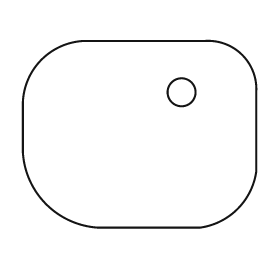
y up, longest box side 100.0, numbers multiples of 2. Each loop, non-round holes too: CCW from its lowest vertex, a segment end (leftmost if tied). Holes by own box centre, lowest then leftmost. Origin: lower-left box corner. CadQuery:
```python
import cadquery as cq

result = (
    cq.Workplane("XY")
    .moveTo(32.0, 0.0)
    .lineTo(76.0, 0.0)
    .threePointArc((92.0, 8.0), (100.0, 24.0))
    .lineTo(100.0, 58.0)
    .threePointArc((94.0, 74.0), (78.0, 80.0))
    .lineTo(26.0, 80.0)
    .threePointArc((8.0, 72.0), (0.0, 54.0))
    .lineTo(0.0, 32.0)
    .threePointArc((10.0, 10.0), (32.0, 0.0))
    .close()
    .moveTo(68.0, 58.0)
    .circle(6.0)
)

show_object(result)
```